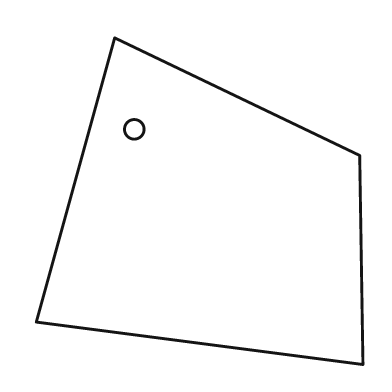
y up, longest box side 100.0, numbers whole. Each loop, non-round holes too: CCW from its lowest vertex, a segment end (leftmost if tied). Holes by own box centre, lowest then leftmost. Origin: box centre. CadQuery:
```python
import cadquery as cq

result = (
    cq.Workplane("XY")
    .moveTo(50.0, -50.0)
    .lineTo(49.0, 14.0)
    .lineTo(-26.0, 50.0)
    .lineTo(-50.0, -37.0)
    .close()
    .moveTo(-20.0, 22.0)
    .circle(3.0)
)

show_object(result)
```